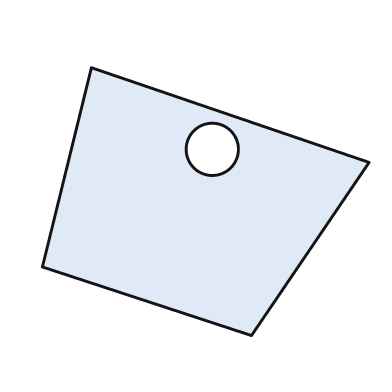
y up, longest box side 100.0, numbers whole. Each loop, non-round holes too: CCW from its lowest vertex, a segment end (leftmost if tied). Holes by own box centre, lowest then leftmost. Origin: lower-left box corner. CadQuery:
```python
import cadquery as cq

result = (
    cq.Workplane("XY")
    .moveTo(64.0, 0.0)
    .lineTo(100.0, 53.0)
    .lineTo(15.0, 82.0)
    .lineTo(0.0, 21.0)
    .close()
    .moveTo(52.0, 57.0)
    .circle(8.0)
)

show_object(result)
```